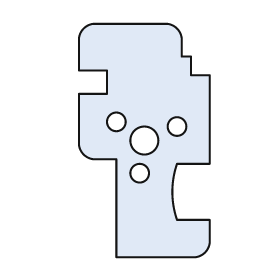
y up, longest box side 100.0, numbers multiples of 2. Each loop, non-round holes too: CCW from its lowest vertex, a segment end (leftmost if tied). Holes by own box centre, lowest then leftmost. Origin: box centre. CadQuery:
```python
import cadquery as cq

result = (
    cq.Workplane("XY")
    .moveTo(-12.0, -50.0)
    .lineTo(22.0, -50.0)
    .threePointArc((26.0, -48.0), (28.0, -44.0))
    .lineTo(28.0, -34.0)
    .lineTo(14.0, -34.0)
    .threePointArc((12.0, -22.0), (14.0, -10.0))
    .lineTo(28.0, -10.0)
    .lineTo(28.0, 28.0)
    .lineTo(20.0, 28.0)
    .lineTo(20.0, 36.0)
    .lineTo(16.0, 36.0)
    .lineTo(16.0, 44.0)
    .threePointArc((14.0, 48.0), (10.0, 50.0))
    .lineTo(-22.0, 50.0)
    .threePointArc((-26.0, 48.0), (-28.0, 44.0))
    .lineTo(-28.0, 30.0)
    .lineTo(-16.0, 30.0)
    .lineTo(-16.0, 20.0)
    .lineTo(-28.0, 20.0)
    .lineTo(-28.0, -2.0)
    .threePointArc((-26.0, -6.0), (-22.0, -8.0))
    .lineTo(-12.0, -8.0)
    .close()
    .moveTo(-2.0, -14.0)
    .circle(4.0)
    .moveTo(0.0, 0.0)
    .circle(6.0)
    .moveTo(14.0, 6.0)
    .circle(4.0)
    .moveTo(-12.0, 8.0)
    .circle(4.0)
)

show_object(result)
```